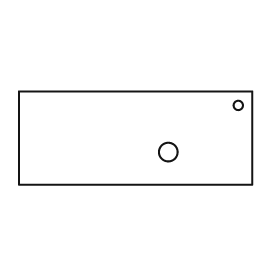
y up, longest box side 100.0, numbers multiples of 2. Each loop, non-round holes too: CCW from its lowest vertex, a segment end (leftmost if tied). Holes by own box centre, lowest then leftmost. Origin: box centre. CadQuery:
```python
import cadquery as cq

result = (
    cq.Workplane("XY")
    .moveTo(-50.0, -20.0)
    .lineTo(50.0, -20.0)
    .lineTo(50.0, 20.0)
    .lineTo(-50.0, 20.0)
    .close()
    .moveTo(14.0, -6.0)
    .circle(4.0)
    .moveTo(44.0, 14.0)
    .circle(2.0)
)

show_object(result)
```